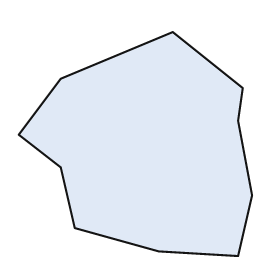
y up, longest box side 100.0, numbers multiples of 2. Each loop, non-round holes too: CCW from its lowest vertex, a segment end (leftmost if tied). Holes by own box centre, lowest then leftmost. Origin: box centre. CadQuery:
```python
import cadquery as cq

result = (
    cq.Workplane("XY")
    .moveTo(44.0, -48.0)
    .lineTo(50.0, -22.0)
    .lineTo(44.0, 10.0)
    .lineTo(46.0, 24.0)
    .lineTo(16.0, 48.0)
    .lineTo(-32.0, 28.0)
    .lineTo(-50.0, 4.0)
    .lineTo(-32.0, -10.0)
    .lineTo(-26.0, -36.0)
    .lineTo(10.0, -46.0)
    .close()
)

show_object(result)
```